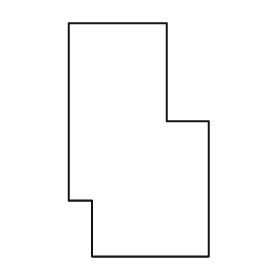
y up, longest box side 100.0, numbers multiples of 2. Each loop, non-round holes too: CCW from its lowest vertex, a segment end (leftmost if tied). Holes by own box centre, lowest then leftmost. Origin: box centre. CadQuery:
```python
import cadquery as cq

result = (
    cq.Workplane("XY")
    .moveTo(-20.0, -50.0)
    .lineTo(30.0, -50.0)
    .lineTo(30.0, 8.0)
    .lineTo(12.0, 8.0)
    .lineTo(12.0, 50.0)
    .lineTo(-30.0, 50.0)
    .lineTo(-30.0, -26.0)
    .lineTo(-20.0, -26.0)
    .close()
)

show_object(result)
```